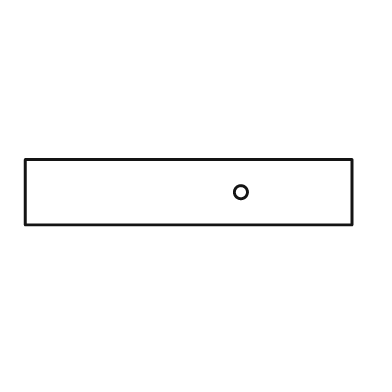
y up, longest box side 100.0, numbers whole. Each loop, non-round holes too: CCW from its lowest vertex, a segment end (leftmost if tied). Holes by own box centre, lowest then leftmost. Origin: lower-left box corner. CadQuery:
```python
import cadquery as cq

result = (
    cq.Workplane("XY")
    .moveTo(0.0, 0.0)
    .lineTo(100.0, 0.0)
    .lineTo(100.0, 20.0)
    .lineTo(0.0, 20.0)
    .close()
    .moveTo(66.0, 10.0)
    .circle(2.0)
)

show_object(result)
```